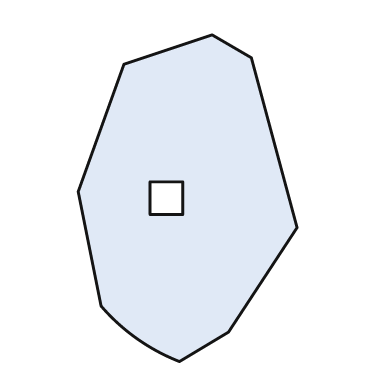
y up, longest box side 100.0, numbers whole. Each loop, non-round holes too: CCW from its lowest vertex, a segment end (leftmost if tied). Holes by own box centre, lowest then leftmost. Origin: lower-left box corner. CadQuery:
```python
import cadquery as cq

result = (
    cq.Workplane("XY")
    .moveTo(31.0, 0.0)
    .lineTo(46.0, 9.0)
    .lineTo(67.0, 41.0)
    .lineTo(53.0, 93.0)
    .lineTo(41.0, 100.0)
    .lineTo(14.0, 91.0)
    .lineTo(0.0, 52.0)
    .lineTo(7.0, 17.0)
    .threePointArc((18.0, 7.0), (31.0, 0.0))
    .close()
    .moveTo(22.0, 45.0)
    .lineTo(32.0, 45.0)
    .lineTo(32.0, 55.0)
    .lineTo(22.0, 55.0)
    .close()
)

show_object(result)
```